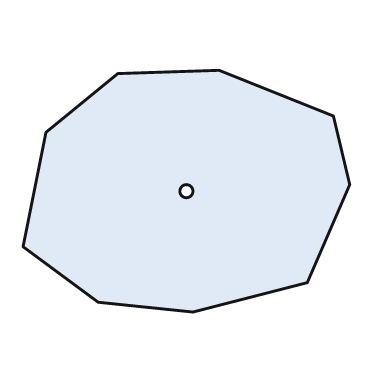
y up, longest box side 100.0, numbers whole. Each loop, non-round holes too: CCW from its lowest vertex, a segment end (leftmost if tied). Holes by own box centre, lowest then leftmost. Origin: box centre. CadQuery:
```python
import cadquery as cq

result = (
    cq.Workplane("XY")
    .moveTo(2.0, -37.0)
    .lineTo(37.0, -28.0)
    .lineTo(50.0, 2.0)
    .lineTo(45.0, 23.0)
    .lineTo(10.0, 37.0)
    .lineTo(-21.0, 36.0)
    .lineTo(-43.0, 18.0)
    .lineTo(-50.0, -17.0)
    .lineTo(-27.0, -34.0)
    .close()
    .moveTo(0.0, 0.0)
    .circle(2.0)
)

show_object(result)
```